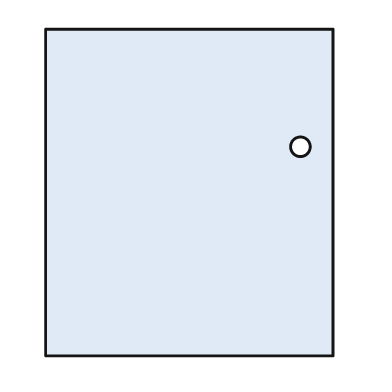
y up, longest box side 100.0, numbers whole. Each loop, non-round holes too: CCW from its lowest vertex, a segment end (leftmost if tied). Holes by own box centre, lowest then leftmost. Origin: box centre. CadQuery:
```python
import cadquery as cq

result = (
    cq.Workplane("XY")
    .moveTo(-44.0, -50.0)
    .lineTo(44.0, -50.0)
    .lineTo(44.0, 50.0)
    .lineTo(-44.0, 50.0)
    .close()
    .moveTo(34.0, 14.0)
    .circle(3.0)
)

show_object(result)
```